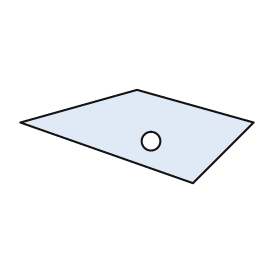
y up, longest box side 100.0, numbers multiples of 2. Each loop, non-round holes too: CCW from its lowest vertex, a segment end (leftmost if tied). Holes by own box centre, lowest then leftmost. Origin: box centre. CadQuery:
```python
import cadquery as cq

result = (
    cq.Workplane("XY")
    .moveTo(24.0, -20.0)
    .lineTo(50.0, 6.0)
    .lineTo(0.0, 20.0)
    .lineTo(-50.0, 6.0)
    .close()
    .moveTo(6.0, -2.0)
    .circle(4.0)
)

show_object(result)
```